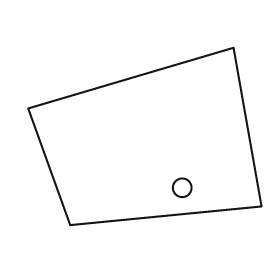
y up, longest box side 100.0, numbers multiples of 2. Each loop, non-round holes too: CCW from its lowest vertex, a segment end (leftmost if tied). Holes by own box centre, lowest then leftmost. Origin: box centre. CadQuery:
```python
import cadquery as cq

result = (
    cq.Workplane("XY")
    .moveTo(-32.0, -38.0)
    .lineTo(50.0, -30.0)
    .lineTo(38.0, 38.0)
    .lineTo(-50.0, 12.0)
    .close()
    .moveTo(16.0, -22.0)
    .circle(4.0)
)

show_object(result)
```